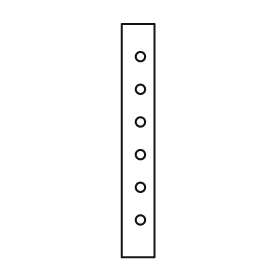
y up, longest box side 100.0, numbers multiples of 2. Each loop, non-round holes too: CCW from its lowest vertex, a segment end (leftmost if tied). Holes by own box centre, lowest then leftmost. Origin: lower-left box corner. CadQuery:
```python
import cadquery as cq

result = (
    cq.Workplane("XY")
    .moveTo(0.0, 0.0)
    .lineTo(14.0, 0.0)
    .lineTo(14.0, 100.0)
    .lineTo(0.0, 100.0)
    .close()
    .moveTo(8.0, 16.0)
    .circle(2.0)
    .moveTo(8.0, 30.0)
    .circle(2.0)
    .moveTo(8.0, 44.0)
    .circle(2.0)
    .moveTo(8.0, 58.0)
    .circle(2.0)
    .moveTo(8.0, 72.0)
    .circle(2.0)
    .moveTo(8.0, 86.0)
    .circle(2.0)
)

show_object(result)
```